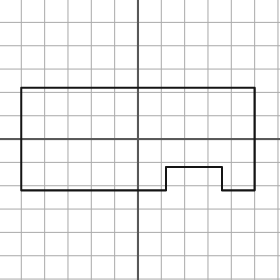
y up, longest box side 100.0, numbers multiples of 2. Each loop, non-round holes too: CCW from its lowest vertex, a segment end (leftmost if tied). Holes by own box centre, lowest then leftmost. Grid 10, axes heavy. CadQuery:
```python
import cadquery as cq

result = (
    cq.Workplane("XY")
    .moveTo(-50.0, -22.0)
    .lineTo(12.0, -22.0)
    .lineTo(12.0, -12.0)
    .lineTo(36.0, -12.0)
    .lineTo(36.0, -22.0)
    .lineTo(50.0, -22.0)
    .lineTo(50.0, 22.0)
    .lineTo(-50.0, 22.0)
    .close()
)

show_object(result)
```